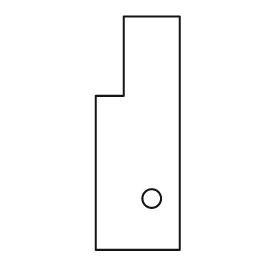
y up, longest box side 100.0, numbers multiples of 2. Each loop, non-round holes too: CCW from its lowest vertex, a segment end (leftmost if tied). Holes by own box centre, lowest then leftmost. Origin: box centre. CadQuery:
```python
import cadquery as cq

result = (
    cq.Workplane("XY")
    .moveTo(-18.0, -50.0)
    .lineTo(18.0, -50.0)
    .lineTo(18.0, 50.0)
    .lineTo(-6.0, 50.0)
    .lineTo(-6.0, 16.0)
    .lineTo(-18.0, 16.0)
    .close()
    .moveTo(6.0, -28.0)
    .circle(4.0)
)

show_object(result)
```